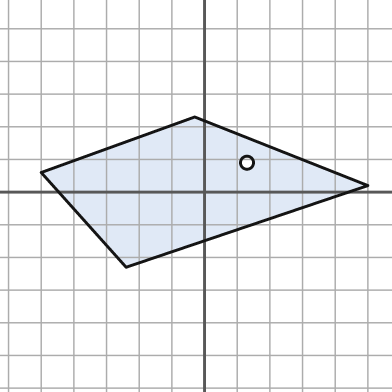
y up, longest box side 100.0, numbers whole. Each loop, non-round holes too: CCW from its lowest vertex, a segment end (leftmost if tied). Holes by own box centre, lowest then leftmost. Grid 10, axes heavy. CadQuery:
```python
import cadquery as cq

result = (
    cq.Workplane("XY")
    .moveTo(-24.0, -23.0)
    .lineTo(50.0, 2.0)
    .lineTo(-3.0, 23.0)
    .lineTo(-50.0, 6.0)
    .close()
    .moveTo(13.0, 9.0)
    .circle(2.0)
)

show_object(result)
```